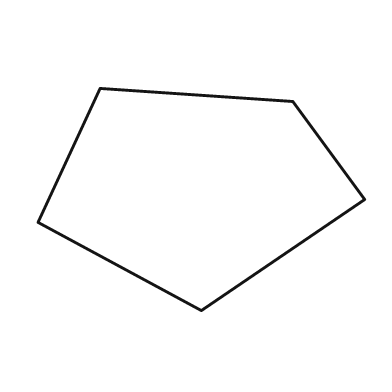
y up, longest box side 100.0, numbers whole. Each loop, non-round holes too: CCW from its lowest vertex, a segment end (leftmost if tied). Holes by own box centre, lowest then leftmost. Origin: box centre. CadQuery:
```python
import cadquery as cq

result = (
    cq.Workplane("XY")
    .moveTo(0.0, -34.0)
    .lineTo(50.0, 0.0)
    .lineTo(28.0, 30.0)
    .lineTo(-31.0, 34.0)
    .lineTo(-50.0, -7.0)
    .close()
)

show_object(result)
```